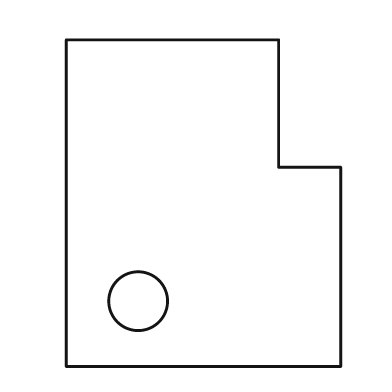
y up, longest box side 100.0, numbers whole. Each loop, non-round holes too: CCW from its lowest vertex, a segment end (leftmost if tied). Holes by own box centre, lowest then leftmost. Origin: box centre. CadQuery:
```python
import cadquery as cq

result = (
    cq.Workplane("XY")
    .moveTo(-42.0, -50.0)
    .lineTo(42.0, -50.0)
    .lineTo(42.0, 11.0)
    .lineTo(23.0, 11.0)
    .lineTo(23.0, 50.0)
    .lineTo(-42.0, 50.0)
    .close()
    .moveTo(-20.0, -30.0)
    .circle(9.0)
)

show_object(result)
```